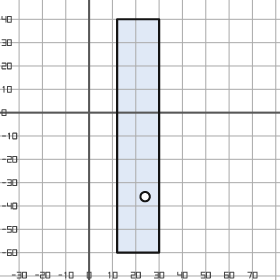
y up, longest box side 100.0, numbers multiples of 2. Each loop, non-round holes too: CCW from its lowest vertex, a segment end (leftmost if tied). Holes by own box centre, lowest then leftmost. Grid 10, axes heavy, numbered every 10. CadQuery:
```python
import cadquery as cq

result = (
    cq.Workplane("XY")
    .moveTo(12.0, -60.0)
    .lineTo(30.0, -60.0)
    .lineTo(30.0, 40.0)
    .lineTo(12.0, 40.0)
    .close()
    .moveTo(24.0, -36.0)
    .circle(2.0)
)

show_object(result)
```